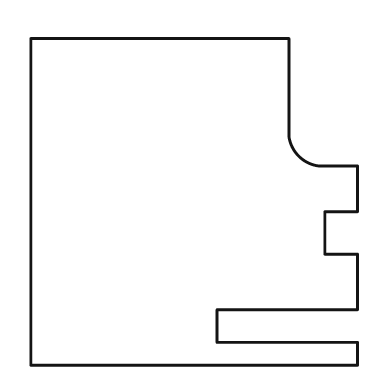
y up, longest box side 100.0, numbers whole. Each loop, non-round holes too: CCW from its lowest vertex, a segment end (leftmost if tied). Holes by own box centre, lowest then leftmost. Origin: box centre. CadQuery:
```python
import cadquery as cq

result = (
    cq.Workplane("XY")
    .moveTo(-50.0, -50.0)
    .lineTo(50.0, -50.0)
    .lineTo(50.0, -43.0)
    .lineTo(7.0, -43.0)
    .lineTo(7.0, -33.0)
    .lineTo(50.0, -33.0)
    .lineTo(50.0, -16.0)
    .lineTo(40.0, -16.0)
    .lineTo(40.0, -3.0)
    .lineTo(50.0, -3.0)
    .lineTo(50.0, 11.0)
    .lineTo(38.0, 11.0)
    .threePointArc((32.0, 14.0), (29.0, 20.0))
    .lineTo(29.0, 50.0)
    .lineTo(-50.0, 50.0)
    .close()
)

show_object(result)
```